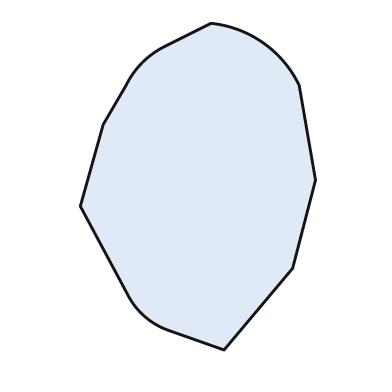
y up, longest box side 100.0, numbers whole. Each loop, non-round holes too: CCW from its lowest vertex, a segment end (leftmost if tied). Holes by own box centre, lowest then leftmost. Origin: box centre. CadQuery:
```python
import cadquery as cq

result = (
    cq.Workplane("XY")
    .moveTo(8.0, -50.0)
    .lineTo(29.0, -25.0)
    .lineTo(36.0, 2.0)
    .lineTo(31.0, 31.0)
    .threePointArc((20.0, 44.0), (4.0, 50.0))
    .lineTo(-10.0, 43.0)
    .threePointArc((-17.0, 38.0), (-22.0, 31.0))
    .lineTo(-29.0, 19.0)
    .lineTo(-36.0, -6.0)
    .lineTo(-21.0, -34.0)
    .threePointArc((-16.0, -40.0), (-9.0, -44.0))
    .close()
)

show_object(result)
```